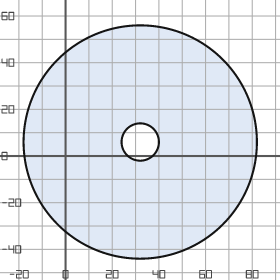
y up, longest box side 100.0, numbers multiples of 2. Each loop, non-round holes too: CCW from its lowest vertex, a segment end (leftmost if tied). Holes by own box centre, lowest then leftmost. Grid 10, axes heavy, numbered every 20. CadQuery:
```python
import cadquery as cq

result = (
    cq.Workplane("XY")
    .moveTo(32.0, 6.0)
    .circle(50.0)
    .moveTo(32.0, 6.0)
    .circle(8.0)
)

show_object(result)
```